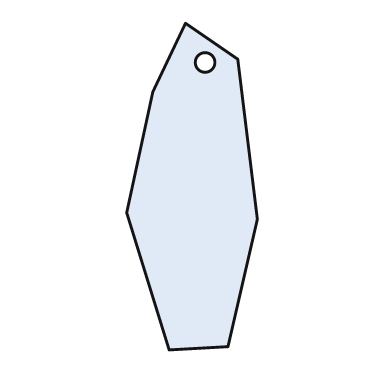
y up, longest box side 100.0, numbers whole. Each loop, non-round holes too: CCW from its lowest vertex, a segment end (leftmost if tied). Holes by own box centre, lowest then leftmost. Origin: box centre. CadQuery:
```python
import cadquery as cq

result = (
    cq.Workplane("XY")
    .moveTo(-7.0, -50.0)
    .lineTo(11.0, -49.0)
    .lineTo(20.0, -10.0)
    .lineTo(14.0, 39.0)
    .lineTo(-2.0, 50.0)
    .lineTo(-12.0, 29.0)
    .lineTo(-20.0, -8.0)
    .close()
    .moveTo(4.0, 38.0)
    .circle(3.0)
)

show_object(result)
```